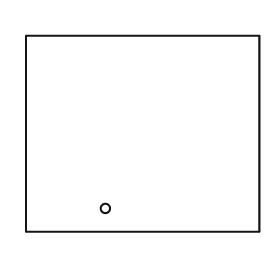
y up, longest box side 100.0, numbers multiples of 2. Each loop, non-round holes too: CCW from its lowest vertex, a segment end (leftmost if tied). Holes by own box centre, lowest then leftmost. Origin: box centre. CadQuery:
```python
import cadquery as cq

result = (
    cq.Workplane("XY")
    .moveTo(-50.0, -42.0)
    .lineTo(50.0, -42.0)
    .lineTo(50.0, 42.0)
    .lineTo(-50.0, 42.0)
    .close()
    .moveTo(-16.0, -32.0)
    .circle(2.0)
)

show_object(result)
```